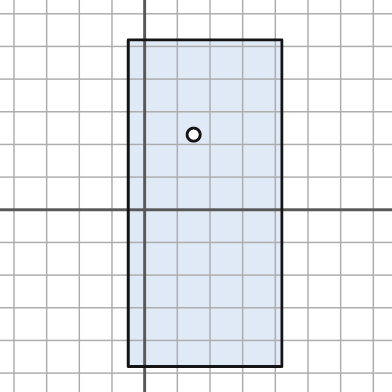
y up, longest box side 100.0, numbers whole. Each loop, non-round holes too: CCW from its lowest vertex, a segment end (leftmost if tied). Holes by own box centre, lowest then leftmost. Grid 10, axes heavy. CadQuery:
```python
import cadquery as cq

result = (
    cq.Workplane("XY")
    .moveTo(-5.0, -48.0)
    .lineTo(42.0, -48.0)
    .lineTo(42.0, 52.0)
    .lineTo(-5.0, 52.0)
    .close()
    .moveTo(15.0, 23.0)
    .circle(2.0)
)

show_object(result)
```